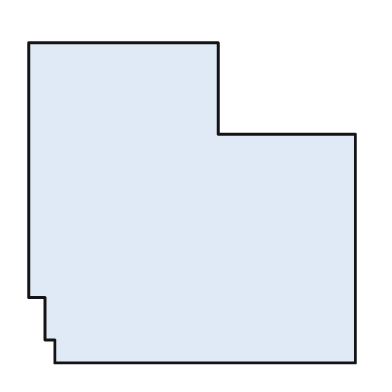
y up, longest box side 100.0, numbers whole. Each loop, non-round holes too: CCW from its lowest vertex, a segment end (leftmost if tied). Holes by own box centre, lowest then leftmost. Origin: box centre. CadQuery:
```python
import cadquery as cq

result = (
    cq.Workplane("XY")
    .moveTo(-42.0, -49.0)
    .lineTo(50.0, -49.0)
    .lineTo(50.0, 21.0)
    .lineTo(8.0, 21.0)
    .lineTo(8.0, 49.0)
    .lineTo(-50.0, 49.0)
    .lineTo(-50.0, -29.0)
    .lineTo(-45.0, -29.0)
    .lineTo(-45.0, -42.0)
    .lineTo(-42.0, -42.0)
    .close()
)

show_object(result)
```